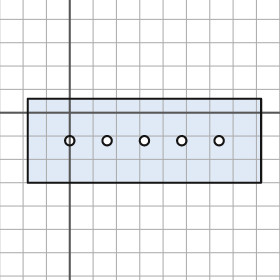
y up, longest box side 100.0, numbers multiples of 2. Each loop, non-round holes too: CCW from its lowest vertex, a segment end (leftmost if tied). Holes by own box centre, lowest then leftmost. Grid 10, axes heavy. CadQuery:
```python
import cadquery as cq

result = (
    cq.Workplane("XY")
    .moveTo(-18.0, -30.0)
    .lineTo(82.0, -30.0)
    .lineTo(82.0, 6.0)
    .lineTo(-18.0, 6.0)
    .close()
    .moveTo(0.0, -12.0)
    .circle(2.0)
    .moveTo(16.0, -12.0)
    .circle(2.0)
    .moveTo(32.0, -12.0)
    .circle(2.0)
    .moveTo(48.0, -12.0)
    .circle(2.0)
    .moveTo(64.0, -12.0)
    .circle(2.0)
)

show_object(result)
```